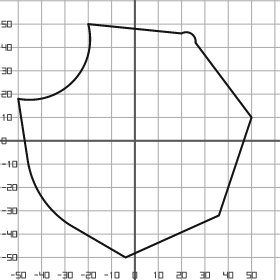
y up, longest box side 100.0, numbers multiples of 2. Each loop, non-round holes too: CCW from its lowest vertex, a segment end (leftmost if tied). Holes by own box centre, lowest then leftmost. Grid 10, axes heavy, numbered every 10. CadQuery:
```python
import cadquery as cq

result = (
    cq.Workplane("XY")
    .moveTo(-4.0, -50.0)
    .lineTo(36.0, -32.0)
    .lineTo(50.0, 10.0)
    .lineTo(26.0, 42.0)
    .threePointArc((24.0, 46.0), (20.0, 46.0))
    .lineTo(-20.0, 50.0)
    .threePointArc((-26.0, 26.0), (-50.0, 18.0))
    .lineTo(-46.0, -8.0)
    .threePointArc((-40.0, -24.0), (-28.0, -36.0))
    .close()
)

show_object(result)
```